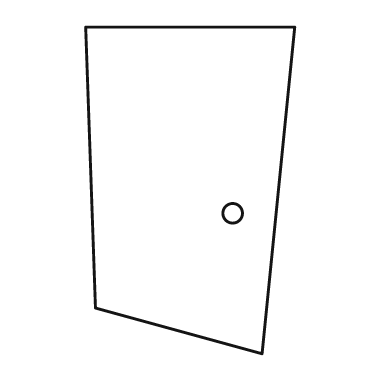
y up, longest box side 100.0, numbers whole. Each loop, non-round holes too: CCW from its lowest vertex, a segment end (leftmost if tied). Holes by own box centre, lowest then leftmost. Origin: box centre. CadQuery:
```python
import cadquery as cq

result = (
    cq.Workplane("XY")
    .moveTo(22.0, -50.0)
    .lineTo(32.0, 50.0)
    .lineTo(-32.0, 50.0)
    .lineTo(-29.0, -36.0)
    .close()
    .moveTo(13.0, -7.0)
    .circle(3.0)
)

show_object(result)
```